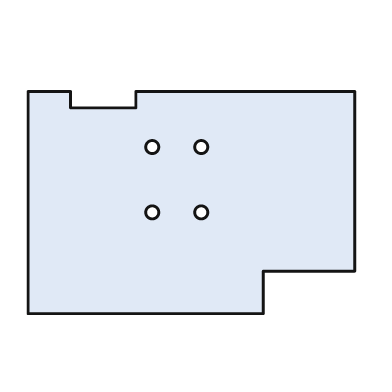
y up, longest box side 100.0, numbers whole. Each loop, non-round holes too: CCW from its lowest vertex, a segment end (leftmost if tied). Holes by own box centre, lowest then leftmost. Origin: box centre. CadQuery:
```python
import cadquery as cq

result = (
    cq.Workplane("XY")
    .moveTo(-50.0, -34.0)
    .lineTo(22.0, -34.0)
    .lineTo(22.0, -21.0)
    .lineTo(50.0, -21.0)
    .lineTo(50.0, 34.0)
    .lineTo(-17.0, 34.0)
    .lineTo(-17.0, 29.0)
    .lineTo(-37.0, 29.0)
    .lineTo(-37.0, 34.0)
    .lineTo(-50.0, 34.0)
    .close()
    .moveTo(-12.0, -3.0)
    .circle(2.0)
    .moveTo(3.0, -3.0)
    .circle(2.0)
    .moveTo(-12.0, 17.0)
    .circle(2.0)
    .moveTo(3.0, 17.0)
    .circle(2.0)
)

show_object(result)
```